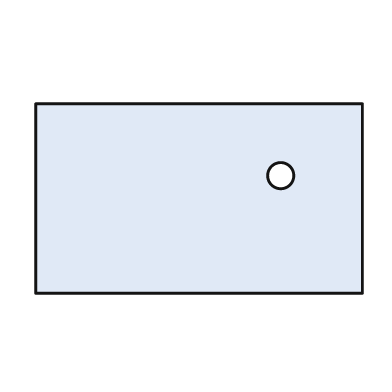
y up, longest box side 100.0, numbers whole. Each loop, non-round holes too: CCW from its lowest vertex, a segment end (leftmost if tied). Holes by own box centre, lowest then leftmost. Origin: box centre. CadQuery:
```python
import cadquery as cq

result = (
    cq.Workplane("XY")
    .moveTo(-50.0, -29.0)
    .lineTo(50.0, -29.0)
    .lineTo(50.0, 29.0)
    .lineTo(-50.0, 29.0)
    .close()
    .moveTo(25.0, 7.0)
    .circle(4.0)
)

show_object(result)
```